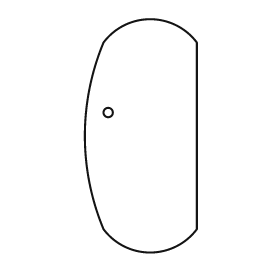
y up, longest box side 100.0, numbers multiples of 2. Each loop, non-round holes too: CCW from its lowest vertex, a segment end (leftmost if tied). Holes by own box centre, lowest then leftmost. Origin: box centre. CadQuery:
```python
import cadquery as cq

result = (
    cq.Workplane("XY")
    .moveTo(-16.0, -40.0)
    .threePointArc((4.0, -50.0), (24.0, -40.0))
    .lineTo(24.0, 40.0)
    .threePointArc((4.0, 50.0), (-16.0, 40.0))
    .threePointArc((-24.0, 0.0), (-16.0, -40.0))
    .close()
    .moveTo(-14.0, 10.0)
    .circle(2.0)
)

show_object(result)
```